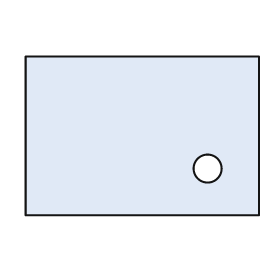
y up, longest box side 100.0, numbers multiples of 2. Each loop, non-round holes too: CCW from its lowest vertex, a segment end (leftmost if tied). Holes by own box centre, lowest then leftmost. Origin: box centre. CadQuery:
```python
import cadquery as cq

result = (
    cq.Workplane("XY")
    .moveTo(-50.0, -34.0)
    .lineTo(50.0, -34.0)
    .lineTo(50.0, 34.0)
    .lineTo(-50.0, 34.0)
    .close()
    .moveTo(28.0, -14.0)
    .circle(6.0)
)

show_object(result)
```